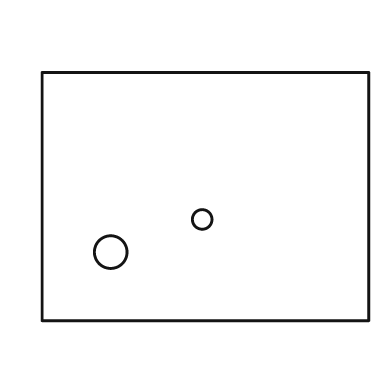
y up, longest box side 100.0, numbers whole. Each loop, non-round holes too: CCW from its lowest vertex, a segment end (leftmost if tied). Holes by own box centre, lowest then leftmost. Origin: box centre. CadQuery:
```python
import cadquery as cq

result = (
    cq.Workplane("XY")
    .moveTo(-50.0, -38.0)
    .lineTo(50.0, -38.0)
    .lineTo(50.0, 38.0)
    .lineTo(-50.0, 38.0)
    .close()
    .moveTo(-29.0, -17.0)
    .circle(5.0)
    .moveTo(-1.0, -7.0)
    .circle(3.0)
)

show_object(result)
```